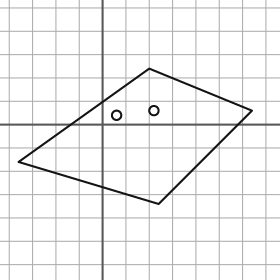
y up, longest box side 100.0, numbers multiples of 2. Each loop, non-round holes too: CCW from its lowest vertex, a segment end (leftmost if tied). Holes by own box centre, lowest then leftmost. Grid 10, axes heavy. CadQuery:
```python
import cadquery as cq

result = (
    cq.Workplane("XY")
    .moveTo(24.0, -34.0)
    .lineTo(64.0, 6.0)
    .lineTo(20.0, 24.0)
    .lineTo(-36.0, -16.0)
    .close()
    .moveTo(6.0, 4.0)
    .circle(2.0)
    .moveTo(22.0, 6.0)
    .circle(2.0)
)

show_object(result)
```